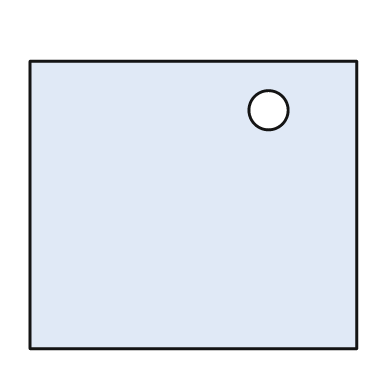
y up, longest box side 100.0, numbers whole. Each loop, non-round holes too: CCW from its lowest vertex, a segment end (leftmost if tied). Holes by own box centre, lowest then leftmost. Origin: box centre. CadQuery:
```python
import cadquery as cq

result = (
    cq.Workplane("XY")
    .moveTo(-50.0, -44.0)
    .lineTo(50.0, -44.0)
    .lineTo(50.0, 44.0)
    .lineTo(-50.0, 44.0)
    .close()
    .moveTo(23.0, 29.0)
    .circle(6.0)
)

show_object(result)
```